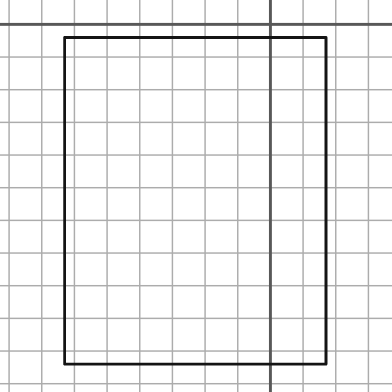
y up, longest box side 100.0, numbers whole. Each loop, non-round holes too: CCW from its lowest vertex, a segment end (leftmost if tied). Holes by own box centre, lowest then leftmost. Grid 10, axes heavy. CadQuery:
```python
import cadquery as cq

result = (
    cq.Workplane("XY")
    .moveTo(-63.0, -104.0)
    .lineTo(17.0, -104.0)
    .lineTo(17.0, -4.0)
    .lineTo(-63.0, -4.0)
    .close()
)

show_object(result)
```